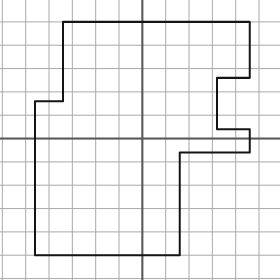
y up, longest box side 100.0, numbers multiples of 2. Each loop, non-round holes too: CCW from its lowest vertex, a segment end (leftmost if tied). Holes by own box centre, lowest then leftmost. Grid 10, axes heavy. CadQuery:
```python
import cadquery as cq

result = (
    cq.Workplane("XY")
    .moveTo(-46.0, -50.0)
    .lineTo(16.0, -50.0)
    .lineTo(16.0, -6.0)
    .lineTo(46.0, -6.0)
    .lineTo(46.0, 4.0)
    .lineTo(32.0, 4.0)
    .lineTo(32.0, 26.0)
    .lineTo(46.0, 26.0)
    .lineTo(46.0, 50.0)
    .lineTo(-34.0, 50.0)
    .lineTo(-34.0, 16.0)
    .lineTo(-46.0, 16.0)
    .close()
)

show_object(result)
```